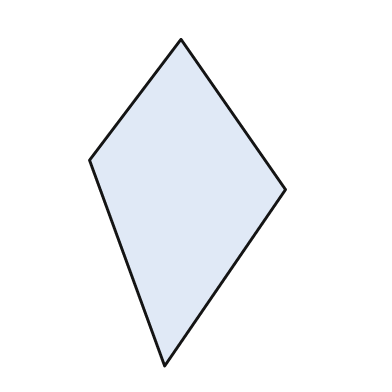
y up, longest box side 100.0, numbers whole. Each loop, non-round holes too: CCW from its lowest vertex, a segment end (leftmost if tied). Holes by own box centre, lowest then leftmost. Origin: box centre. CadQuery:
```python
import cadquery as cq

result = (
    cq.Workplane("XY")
    .moveTo(-7.0, -50.0)
    .lineTo(30.0, 4.0)
    .lineTo(-2.0, 50.0)
    .lineTo(-30.0, 13.0)
    .close()
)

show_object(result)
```